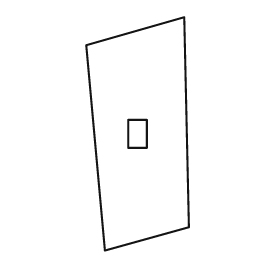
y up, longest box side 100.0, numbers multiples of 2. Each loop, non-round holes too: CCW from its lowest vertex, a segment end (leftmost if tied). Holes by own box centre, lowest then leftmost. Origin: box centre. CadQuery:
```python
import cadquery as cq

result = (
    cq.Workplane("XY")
    .moveTo(-14.0, -50.0)
    .lineTo(22.0, -40.0)
    .lineTo(20.0, 50.0)
    .lineTo(-22.0, 38.0)
    .close()
    .moveTo(-4.0, -6.0)
    .lineTo(4.0, -6.0)
    .lineTo(4.0, 6.0)
    .lineTo(-4.0, 6.0)
    .close()
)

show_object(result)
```